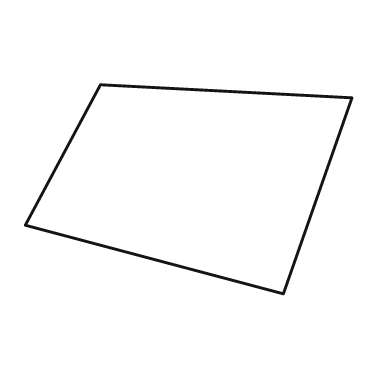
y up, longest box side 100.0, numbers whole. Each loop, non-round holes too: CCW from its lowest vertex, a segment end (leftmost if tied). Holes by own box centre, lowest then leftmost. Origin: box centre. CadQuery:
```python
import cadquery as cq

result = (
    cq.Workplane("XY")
    .moveTo(29.0, -32.0)
    .lineTo(50.0, 28.0)
    .lineTo(-27.0, 32.0)
    .lineTo(-50.0, -11.0)
    .close()
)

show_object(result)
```